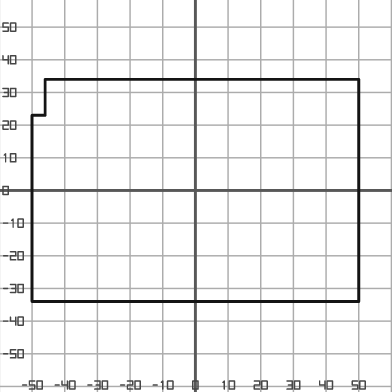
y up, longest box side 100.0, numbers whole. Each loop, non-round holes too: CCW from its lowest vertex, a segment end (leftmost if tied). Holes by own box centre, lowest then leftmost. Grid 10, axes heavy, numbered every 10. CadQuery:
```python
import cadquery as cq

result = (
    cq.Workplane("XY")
    .moveTo(-50.0, -34.0)
    .lineTo(50.0, -34.0)
    .lineTo(50.0, 34.0)
    .lineTo(-46.0, 34.0)
    .lineTo(-46.0, 23.0)
    .lineTo(-50.0, 23.0)
    .close()
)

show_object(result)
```